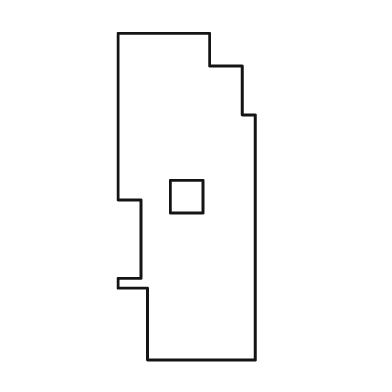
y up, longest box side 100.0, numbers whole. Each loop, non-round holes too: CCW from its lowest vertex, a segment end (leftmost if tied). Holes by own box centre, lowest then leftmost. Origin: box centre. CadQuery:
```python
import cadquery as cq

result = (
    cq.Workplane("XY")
    .moveTo(-12.0, -50.0)
    .lineTo(21.0, -50.0)
    .lineTo(21.0, 25.0)
    .lineTo(17.0, 25.0)
    .lineTo(17.0, 40.0)
    .lineTo(7.0, 40.0)
    .lineTo(7.0, 50.0)
    .lineTo(-21.0, 50.0)
    .lineTo(-21.0, -1.0)
    .lineTo(-14.0, -1.0)
    .lineTo(-14.0, -25.0)
    .lineTo(-21.0, -25.0)
    .lineTo(-21.0, -28.0)
    .lineTo(-12.0, -28.0)
    .close()
    .moveTo(-5.0, -5.0)
    .lineTo(5.0, -5.0)
    .lineTo(5.0, 5.0)
    .lineTo(-5.0, 5.0)
    .close()
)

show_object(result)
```